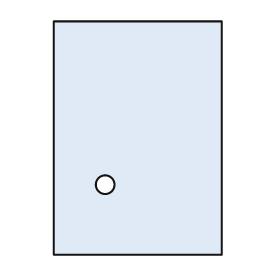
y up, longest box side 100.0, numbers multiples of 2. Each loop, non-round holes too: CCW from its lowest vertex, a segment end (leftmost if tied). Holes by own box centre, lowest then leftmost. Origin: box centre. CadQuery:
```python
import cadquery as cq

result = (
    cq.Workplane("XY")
    .moveTo(-36.0, -50.0)
    .lineTo(36.0, -50.0)
    .lineTo(36.0, 50.0)
    .lineTo(-36.0, 50.0)
    .close()
    .moveTo(-14.0, -20.0)
    .circle(4.0)
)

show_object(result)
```